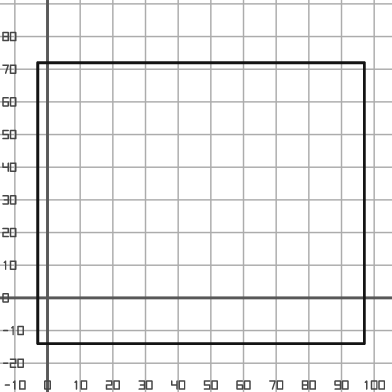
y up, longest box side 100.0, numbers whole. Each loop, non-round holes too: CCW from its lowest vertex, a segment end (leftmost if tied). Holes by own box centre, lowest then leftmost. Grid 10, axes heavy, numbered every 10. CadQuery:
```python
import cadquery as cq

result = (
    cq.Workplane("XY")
    .moveTo(-3.0, -14.0)
    .lineTo(97.0, -14.0)
    .lineTo(97.0, 72.0)
    .lineTo(-3.0, 72.0)
    .close()
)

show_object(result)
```